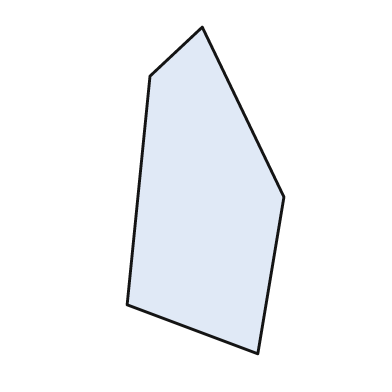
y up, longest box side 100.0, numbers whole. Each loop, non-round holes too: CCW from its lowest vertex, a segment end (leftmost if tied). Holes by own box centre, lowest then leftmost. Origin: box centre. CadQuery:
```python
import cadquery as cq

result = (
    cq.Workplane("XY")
    .moveTo(16.0, -50.0)
    .lineTo(24.0, -2.0)
    .lineTo(-1.0, 50.0)
    .lineTo(-17.0, 35.0)
    .lineTo(-24.0, -35.0)
    .close()
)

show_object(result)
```